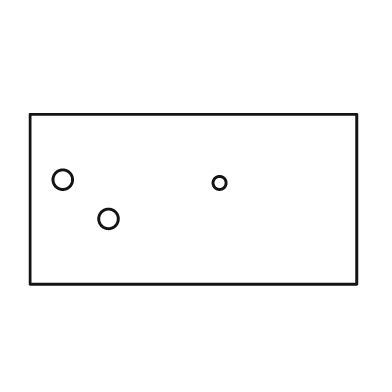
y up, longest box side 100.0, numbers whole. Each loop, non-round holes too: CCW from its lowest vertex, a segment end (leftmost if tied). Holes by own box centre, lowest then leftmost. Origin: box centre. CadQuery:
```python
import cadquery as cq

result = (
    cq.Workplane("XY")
    .moveTo(-50.0, -26.0)
    .lineTo(50.0, -26.0)
    .lineTo(50.0, 26.0)
    .lineTo(-50.0, 26.0)
    .close()
    .moveTo(-26.0, -6.0)
    .circle(3.0)
    .moveTo(8.0, 5.0)
    .circle(2.0)
    .moveTo(-40.0, 6.0)
    .circle(3.0)
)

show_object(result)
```